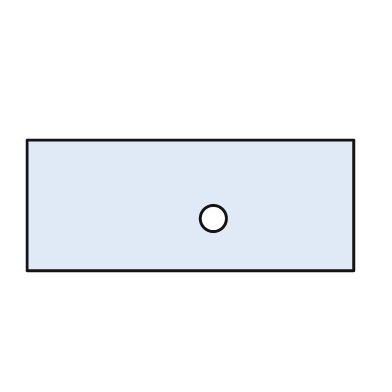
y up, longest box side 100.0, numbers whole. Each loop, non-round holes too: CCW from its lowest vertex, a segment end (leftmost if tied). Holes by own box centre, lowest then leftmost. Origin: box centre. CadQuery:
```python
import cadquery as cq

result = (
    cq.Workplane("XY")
    .moveTo(-50.0, -20.0)
    .lineTo(50.0, -20.0)
    .lineTo(50.0, 20.0)
    .lineTo(-50.0, 20.0)
    .close()
    .moveTo(7.0, -4.0)
    .circle(4.0)
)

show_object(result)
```